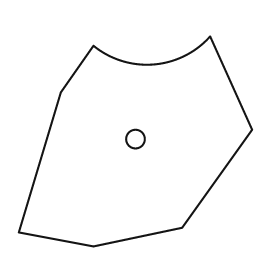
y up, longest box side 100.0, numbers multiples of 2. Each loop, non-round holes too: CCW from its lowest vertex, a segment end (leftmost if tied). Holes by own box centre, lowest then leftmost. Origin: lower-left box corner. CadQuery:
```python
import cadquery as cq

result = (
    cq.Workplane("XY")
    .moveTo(32.0, 0.0)
    .lineTo(70.0, 8.0)
    .lineTo(100.0, 50.0)
    .lineTo(82.0, 90.0)
    .threePointArc((58.0, 78.0), (32.0, 86.0))
    .lineTo(18.0, 66.0)
    .lineTo(0.0, 6.0)
    .close()
    .moveTo(50.0, 46.0)
    .circle(4.0)
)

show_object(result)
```